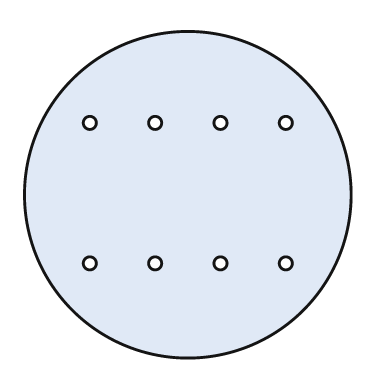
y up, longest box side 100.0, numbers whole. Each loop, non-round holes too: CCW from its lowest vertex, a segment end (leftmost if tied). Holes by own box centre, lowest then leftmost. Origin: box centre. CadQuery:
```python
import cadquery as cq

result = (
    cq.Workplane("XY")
    .moveTo(0.0, 0.0)
    .circle(50.0)
    .moveTo(-30.0, -21.0)
    .circle(2.0)
    .moveTo(-10.0, -21.0)
    .circle(2.0)
    .moveTo(10.0, -21.0)
    .circle(2.0)
    .moveTo(30.0, -21.0)
    .circle(2.0)
    .moveTo(-30.0, 22.0)
    .circle(2.0)
    .moveTo(-10.0, 22.0)
    .circle(2.0)
    .moveTo(10.0, 22.0)
    .circle(2.0)
    .moveTo(30.0, 22.0)
    .circle(2.0)
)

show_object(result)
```